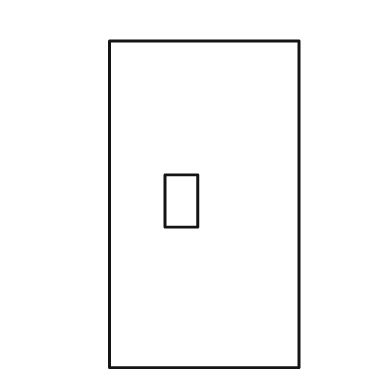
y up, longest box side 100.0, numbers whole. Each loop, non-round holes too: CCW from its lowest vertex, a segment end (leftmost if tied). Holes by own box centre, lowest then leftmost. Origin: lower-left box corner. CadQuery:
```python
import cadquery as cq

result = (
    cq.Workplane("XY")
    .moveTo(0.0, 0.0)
    .lineTo(58.0, 0.0)
    .lineTo(58.0, 100.0)
    .lineTo(0.0, 100.0)
    .close()
    .moveTo(17.0, 43.0)
    .lineTo(27.0, 43.0)
    .lineTo(27.0, 59.0)
    .lineTo(17.0, 59.0)
    .close()
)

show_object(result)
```